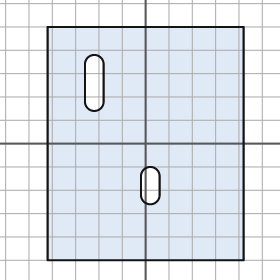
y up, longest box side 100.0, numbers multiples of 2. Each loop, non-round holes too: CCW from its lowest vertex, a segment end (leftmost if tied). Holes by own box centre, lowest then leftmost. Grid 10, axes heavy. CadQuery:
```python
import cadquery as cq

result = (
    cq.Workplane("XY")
    .moveTo(-42.0, -50.0)
    .lineTo(42.0, -50.0)
    .lineTo(42.0, 50.0)
    .lineTo(-42.0, 50.0)
    .close()
    .moveTo(-2.0, -22.0)
    .threePointArc((2.0, -26.0), (6.0, -22.0))
    .lineTo(6.0, -14.0)
    .threePointArc((2.0, -10.0), (-2.0, -14.0))
    .close()
    .moveTo(-26.0, 18.0)
    .threePointArc((-22.0, 14.0), (-18.0, 18.0))
    .lineTo(-18.0, 34.0)
    .threePointArc((-22.0, 38.0), (-26.0, 34.0))
    .close()
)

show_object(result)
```